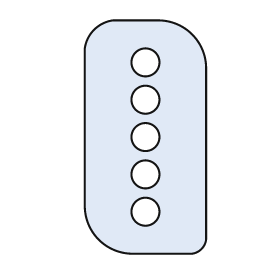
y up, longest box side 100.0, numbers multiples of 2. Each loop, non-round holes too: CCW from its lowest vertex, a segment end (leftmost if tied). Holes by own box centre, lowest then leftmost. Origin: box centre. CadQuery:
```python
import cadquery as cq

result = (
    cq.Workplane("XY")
    .moveTo(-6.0, -50.0)
    .lineTo(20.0, -50.0)
    .threePointArc((24.0, -48.0), (26.0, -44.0))
    .lineTo(26.0, 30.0)
    .threePointArc((20.0, 44.0), (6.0, 50.0))
    .lineTo(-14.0, 50.0)
    .threePointArc((-22.0, 46.0), (-26.0, 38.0))
    .lineTo(-26.0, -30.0)
    .threePointArc((-20.0, -44.0), (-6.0, -50.0))
    .close()
    .moveTo(0.0, -32.0)
    .circle(6.0)
    .moveTo(0.0, -16.0)
    .circle(6.0)
    .moveTo(0.0, 0.0)
    .circle(6.0)
    .moveTo(0.0, 16.0)
    .circle(6.0)
    .moveTo(0.0, 32.0)
    .circle(6.0)
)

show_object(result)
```